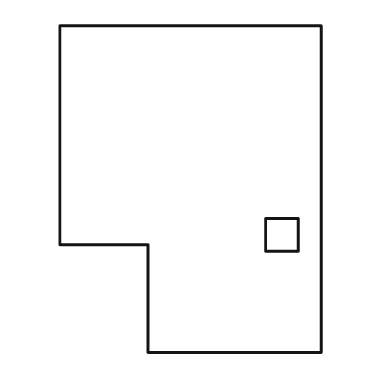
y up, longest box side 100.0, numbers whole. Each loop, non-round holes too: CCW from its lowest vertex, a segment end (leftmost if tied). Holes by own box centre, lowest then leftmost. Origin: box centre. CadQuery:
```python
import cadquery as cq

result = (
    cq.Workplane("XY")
    .moveTo(-13.0, -50.0)
    .lineTo(40.0, -50.0)
    .lineTo(40.0, 50.0)
    .lineTo(-40.0, 50.0)
    .lineTo(-40.0, -17.0)
    .lineTo(-13.0, -17.0)
    .close()
    .moveTo(23.0, -19.0)
    .lineTo(33.0, -19.0)
    .lineTo(33.0, -9.0)
    .lineTo(23.0, -9.0)
    .close()
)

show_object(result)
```